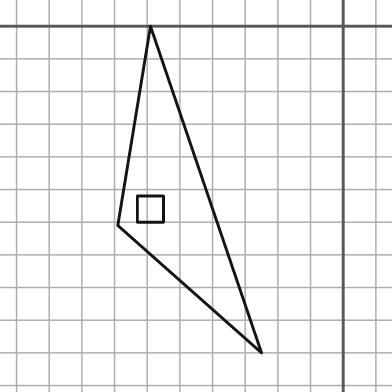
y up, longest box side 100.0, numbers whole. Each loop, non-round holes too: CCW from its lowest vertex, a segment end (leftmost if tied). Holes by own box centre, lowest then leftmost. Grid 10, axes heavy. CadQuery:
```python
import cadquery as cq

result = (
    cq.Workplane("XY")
    .moveTo(-25.0, -100.0)
    .lineTo(-59.0, 0.0)
    .lineTo(-69.0, -61.0)
    .close()
    .moveTo(-63.0, -60.0)
    .lineTo(-55.0, -60.0)
    .lineTo(-55.0, -52.0)
    .lineTo(-63.0, -52.0)
    .close()
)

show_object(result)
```